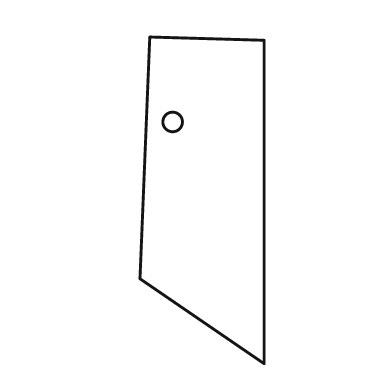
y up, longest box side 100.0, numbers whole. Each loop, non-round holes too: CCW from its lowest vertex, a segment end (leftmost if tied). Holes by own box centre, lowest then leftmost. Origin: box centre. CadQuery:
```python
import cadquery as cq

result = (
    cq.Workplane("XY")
    .moveTo(19.0, -50.0)
    .lineTo(19.0, 49.0)
    .lineTo(-16.0, 50.0)
    .lineTo(-19.0, -24.0)
    .close()
    .moveTo(-9.0, 24.0)
    .circle(3.0)
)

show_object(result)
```